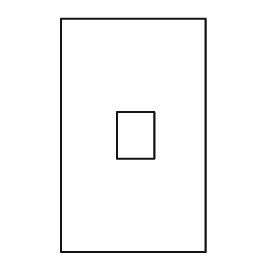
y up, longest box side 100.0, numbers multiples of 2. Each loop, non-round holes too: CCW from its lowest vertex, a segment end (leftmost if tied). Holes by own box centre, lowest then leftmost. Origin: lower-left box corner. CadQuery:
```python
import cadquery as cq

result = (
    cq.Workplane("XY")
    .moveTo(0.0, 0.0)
    .lineTo(62.0, 0.0)
    .lineTo(62.0, 100.0)
    .lineTo(0.0, 100.0)
    .close()
    .moveTo(24.0, 40.0)
    .lineTo(40.0, 40.0)
    .lineTo(40.0, 60.0)
    .lineTo(24.0, 60.0)
    .close()
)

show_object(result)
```